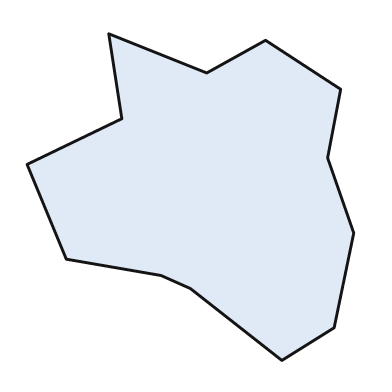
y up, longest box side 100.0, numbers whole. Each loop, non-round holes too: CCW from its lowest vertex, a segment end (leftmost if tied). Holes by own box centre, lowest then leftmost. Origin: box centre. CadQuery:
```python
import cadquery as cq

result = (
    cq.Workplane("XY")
    .moveTo(28.0, -50.0)
    .lineTo(44.0, -40.0)
    .lineTo(50.0, -11.0)
    .lineTo(42.0, 12.0)
    .lineTo(46.0, 33.0)
    .lineTo(23.0, 48.0)
    .lineTo(5.0, 38.0)
    .lineTo(-25.0, 50.0)
    .lineTo(-21.0, 24.0)
    .lineTo(-50.0, 10.0)
    .lineTo(-38.0, -19.0)
    .lineTo(-9.0, -24.0)
    .lineTo(0.0, -28.0)
    .close()
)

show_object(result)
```